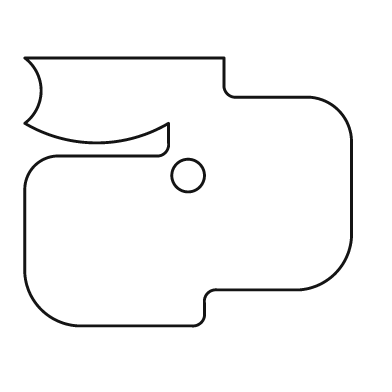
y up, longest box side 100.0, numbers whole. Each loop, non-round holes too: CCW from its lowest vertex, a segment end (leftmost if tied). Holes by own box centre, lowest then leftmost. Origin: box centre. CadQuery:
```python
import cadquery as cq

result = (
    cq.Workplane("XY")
    .moveTo(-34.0, -41.0)
    .lineTo(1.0, -41.0)
    .threePointArc((4.0, -40.0), (5.0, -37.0))
    .lineTo(5.0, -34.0)
    .threePointArc((6.0, -31.0), (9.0, -30.0))
    .lineTo(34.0, -30.0)
    .threePointArc((45.0, -25.0), (50.0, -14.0))
    .lineTo(50.0, 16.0)
    .threePointArc((46.0, 25.0), (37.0, 29.0))
    .lineTo(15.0, 29.0)
    .threePointArc((12.0, 30.0), (11.0, 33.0))
    .lineTo(11.0, 41.0)
    .lineTo(-50.0, 41.0)
    .threePointArc((-45.0, 31.0), (-50.0, 21.0))
    .threePointArc((-28.0, 15.0), (-6.0, 21.0))
    .lineTo(-6.0, 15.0)
    .threePointArc((-7.0, 12.0), (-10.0, 11.0))
    .lineTo(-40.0, 11.0)
    .threePointArc((-47.0, 8.0), (-50.0, 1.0))
    .lineTo(-50.0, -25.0)
    .threePointArc((-45.0, -36.0), (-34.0, -41.0))
    .close()
    .moveTo(0.0, 5.0)
    .circle(5.0)
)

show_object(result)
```